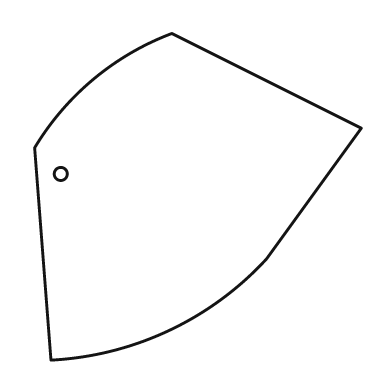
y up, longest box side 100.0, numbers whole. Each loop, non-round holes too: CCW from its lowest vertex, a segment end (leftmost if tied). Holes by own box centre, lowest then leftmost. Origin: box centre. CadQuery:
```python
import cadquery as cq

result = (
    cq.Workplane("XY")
    .moveTo(-45.0, -50.0)
    .threePointArc((-9.0, -41.0), (21.0, -19.0))
    .lineTo(50.0, 21.0)
    .lineTo(-8.0, 50.0)
    .threePointArc((-32.0, 36.0), (-50.0, 15.0))
    .close()
    .moveTo(-42.0, 7.0)
    .circle(2.0)
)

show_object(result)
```